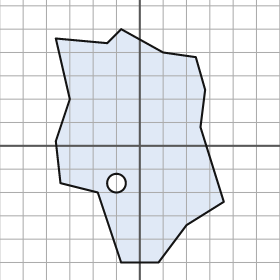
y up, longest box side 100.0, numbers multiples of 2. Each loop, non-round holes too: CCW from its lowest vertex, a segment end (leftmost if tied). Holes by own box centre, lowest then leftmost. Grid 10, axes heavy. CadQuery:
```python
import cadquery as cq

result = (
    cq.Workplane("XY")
    .moveTo(-8.0, -50.0)
    .lineTo(8.0, -50.0)
    .lineTo(20.0, -34.0)
    .lineTo(36.0, -24.0)
    .lineTo(26.0, 8.0)
    .lineTo(28.0, 24.0)
    .lineTo(24.0, 38.0)
    .lineTo(10.0, 40.0)
    .lineTo(-8.0, 50.0)
    .lineTo(-14.0, 44.0)
    .lineTo(-36.0, 46.0)
    .lineTo(-30.0, 20.0)
    .lineTo(-36.0, 2.0)
    .lineTo(-34.0, -16.0)
    .lineTo(-18.0, -20.0)
    .close()
    .moveTo(-10.0, -16.0)
    .circle(4.0)
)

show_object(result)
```